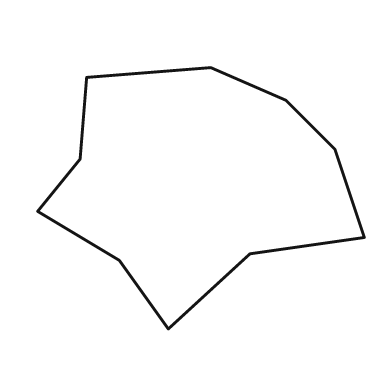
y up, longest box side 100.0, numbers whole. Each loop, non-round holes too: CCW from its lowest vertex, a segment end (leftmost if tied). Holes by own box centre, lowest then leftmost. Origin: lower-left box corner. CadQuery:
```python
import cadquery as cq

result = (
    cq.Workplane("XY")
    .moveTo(40.0, 0.0)
    .lineTo(65.0, 23.0)
    .lineTo(100.0, 28.0)
    .lineTo(91.0, 55.0)
    .lineTo(76.0, 70.0)
    .lineTo(53.0, 80.0)
    .lineTo(15.0, 77.0)
    .lineTo(13.0, 52.0)
    .lineTo(0.0, 36.0)
    .lineTo(25.0, 21.0)
    .close()
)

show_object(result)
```